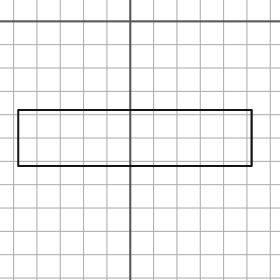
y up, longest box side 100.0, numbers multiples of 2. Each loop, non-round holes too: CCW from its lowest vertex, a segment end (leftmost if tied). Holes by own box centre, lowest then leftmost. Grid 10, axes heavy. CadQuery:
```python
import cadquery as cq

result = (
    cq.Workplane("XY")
    .moveTo(-48.0, -62.0)
    .lineTo(52.0, -62.0)
    .lineTo(52.0, -38.0)
    .lineTo(-48.0, -38.0)
    .close()
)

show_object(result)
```